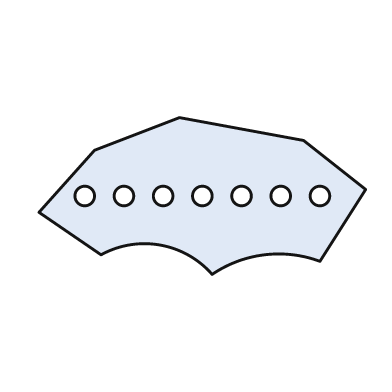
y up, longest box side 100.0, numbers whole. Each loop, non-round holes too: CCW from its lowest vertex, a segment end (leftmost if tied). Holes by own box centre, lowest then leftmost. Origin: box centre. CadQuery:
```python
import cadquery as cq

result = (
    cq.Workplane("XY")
    .moveTo(3.0, -24.0)
    .threePointArc((19.0, -18.0), (36.0, -20.0))
    .lineTo(50.0, 2.0)
    .lineTo(31.0, 17.0)
    .lineTo(-7.0, 24.0)
    .lineTo(-33.0, 14.0)
    .lineTo(-50.0, -5.0)
    .lineTo(-31.0, -18.0)
    .threePointArc((-13.0, -15.0), (3.0, -24.0))
    .close()
    .moveTo(-36.0, 0.0)
    .circle(3.0)
    .moveTo(-24.0, 0.0)
    .circle(3.0)
    .moveTo(-12.0, 0.0)
    .circle(3.0)
    .moveTo(0.0, 0.0)
    .circle(3.0)
    .moveTo(12.0, 0.0)
    .circle(3.0)
    .moveTo(24.0, 0.0)
    .circle(3.0)
    .moveTo(36.0, 0.0)
    .circle(3.0)
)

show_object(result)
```